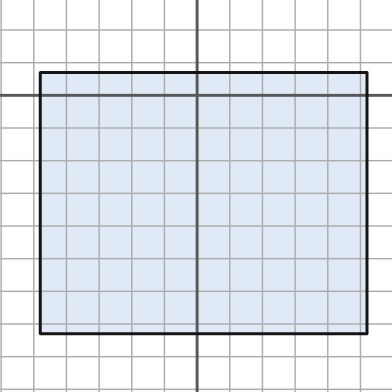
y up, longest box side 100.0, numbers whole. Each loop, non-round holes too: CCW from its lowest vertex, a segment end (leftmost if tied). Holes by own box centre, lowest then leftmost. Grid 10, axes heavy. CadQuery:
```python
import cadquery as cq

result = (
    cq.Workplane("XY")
    .moveTo(-48.0, -73.0)
    .lineTo(52.0, -73.0)
    .lineTo(52.0, 7.0)
    .lineTo(-48.0, 7.0)
    .close()
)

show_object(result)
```